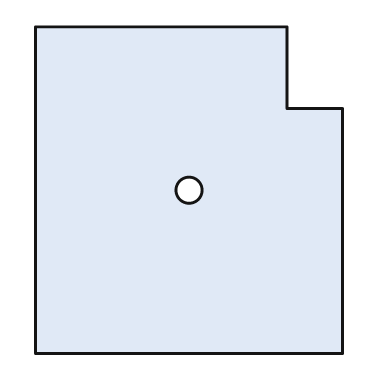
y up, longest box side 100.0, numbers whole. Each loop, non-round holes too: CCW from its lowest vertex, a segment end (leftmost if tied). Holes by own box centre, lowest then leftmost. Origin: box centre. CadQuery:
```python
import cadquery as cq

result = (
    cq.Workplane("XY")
    .moveTo(-47.0, -50.0)
    .lineTo(47.0, -50.0)
    .lineTo(47.0, 25.0)
    .lineTo(30.0, 25.0)
    .lineTo(30.0, 50.0)
    .lineTo(-47.0, 50.0)
    .close()
    .moveTo(0.0, 0.0)
    .circle(4.0)
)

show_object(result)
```